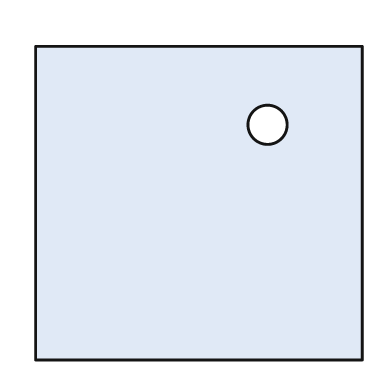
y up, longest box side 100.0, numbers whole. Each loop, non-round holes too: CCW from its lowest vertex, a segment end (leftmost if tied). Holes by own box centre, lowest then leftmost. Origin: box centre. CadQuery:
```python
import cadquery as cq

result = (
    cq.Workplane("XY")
    .moveTo(-50.0, -48.0)
    .lineTo(50.0, -48.0)
    .lineTo(50.0, 48.0)
    .lineTo(-50.0, 48.0)
    .close()
    .moveTo(21.0, 24.0)
    .circle(6.0)
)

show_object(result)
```